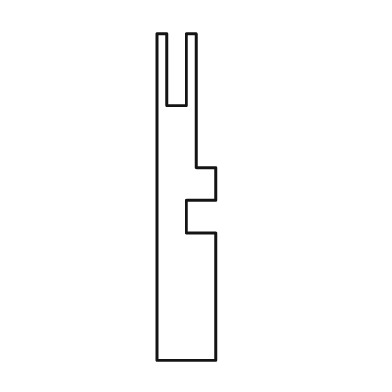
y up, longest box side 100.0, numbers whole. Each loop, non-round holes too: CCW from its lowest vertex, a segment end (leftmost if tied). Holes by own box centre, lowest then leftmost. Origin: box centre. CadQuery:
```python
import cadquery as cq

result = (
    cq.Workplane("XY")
    .moveTo(-9.0, -50.0)
    .lineTo(9.0, -50.0)
    .lineTo(9.0, -11.0)
    .lineTo(0.0, -11.0)
    .lineTo(0.0, -1.0)
    .lineTo(9.0, -1.0)
    .lineTo(9.0, 9.0)
    .lineTo(3.0, 9.0)
    .lineTo(3.0, 50.0)
    .lineTo(0.0, 50.0)
    .lineTo(0.0, 28.0)
    .lineTo(-6.0, 28.0)
    .lineTo(-6.0, 50.0)
    .lineTo(-9.0, 50.0)
    .close()
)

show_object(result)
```